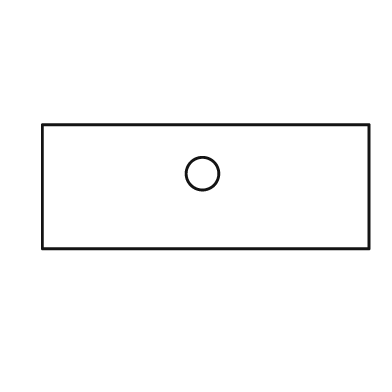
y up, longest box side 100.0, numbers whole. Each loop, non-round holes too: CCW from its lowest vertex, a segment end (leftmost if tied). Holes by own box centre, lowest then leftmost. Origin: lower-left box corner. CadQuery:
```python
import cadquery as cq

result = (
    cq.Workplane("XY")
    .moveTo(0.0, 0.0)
    .lineTo(100.0, 0.0)
    .lineTo(100.0, 38.0)
    .lineTo(0.0, 38.0)
    .close()
    .moveTo(49.0, 23.0)
    .circle(5.0)
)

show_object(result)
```